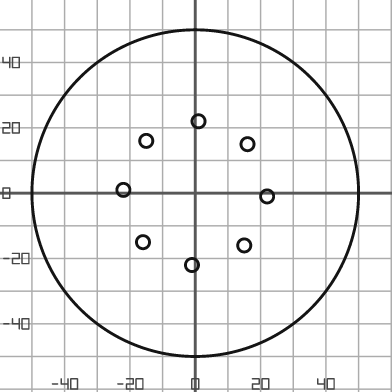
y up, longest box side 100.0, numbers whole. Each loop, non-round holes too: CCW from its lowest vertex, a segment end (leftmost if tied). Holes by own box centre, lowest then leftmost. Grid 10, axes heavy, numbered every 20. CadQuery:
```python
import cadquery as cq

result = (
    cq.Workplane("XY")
    .moveTo(0.0, 0.0)
    .circle(50.0)
    .moveTo(-1.0, -22.0)
    .circle(2.0)
    .moveTo(15.0, -16.0)
    .circle(2.0)
    .moveTo(-16.0, -15.0)
    .circle(2.0)
    .moveTo(22.0, -1.0)
    .circle(2.0)
    .moveTo(-22.0, 1.0)
    .circle(2.0)
    .moveTo(16.0, 15.0)
    .circle(2.0)
    .moveTo(-15.0, 16.0)
    .circle(2.0)
    .moveTo(1.0, 22.0)
    .circle(2.0)
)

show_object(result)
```